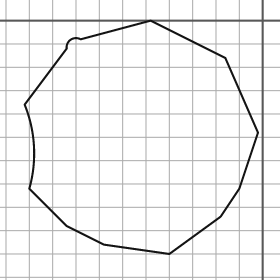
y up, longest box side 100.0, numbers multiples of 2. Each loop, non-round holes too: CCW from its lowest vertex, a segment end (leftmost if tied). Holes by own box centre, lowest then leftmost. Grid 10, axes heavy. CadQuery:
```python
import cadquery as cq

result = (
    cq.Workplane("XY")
    .moveTo(-40.0, -100.0)
    .lineTo(-18.0, -84.0)
    .lineTo(-10.0, -72.0)
    .lineTo(-2.0, -48.0)
    .lineTo(-16.0, -16.0)
    .lineTo(-48.0, 0.0)
    .lineTo(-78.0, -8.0)
    .threePointArc((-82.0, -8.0), (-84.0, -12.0))
    .lineTo(-102.0, -36.0)
    .threePointArc((-98.0, -54.0), (-100.0, -72.0))
    .lineTo(-84.0, -88.0)
    .lineTo(-68.0, -96.0)
    .close()
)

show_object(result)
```